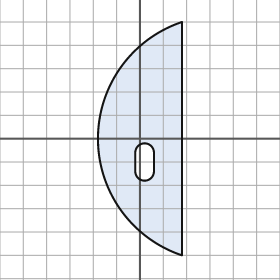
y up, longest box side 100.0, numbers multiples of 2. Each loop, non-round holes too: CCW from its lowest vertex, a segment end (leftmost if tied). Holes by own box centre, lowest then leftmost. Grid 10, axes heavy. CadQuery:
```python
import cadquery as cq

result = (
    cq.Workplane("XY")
    .moveTo(18.0, -50.0)
    .lineTo(18.0, 50.0)
    .threePointArc((-18.0, 0.0), (18.0, -50.0))
    .close()
    .moveTo(-2.0, -14.0)
    .threePointArc((2.0, -18.0), (6.0, -14.0))
    .lineTo(6.0, -6.0)
    .threePointArc((2.0, -2.0), (-2.0, -6.0))
    .close()
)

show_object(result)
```